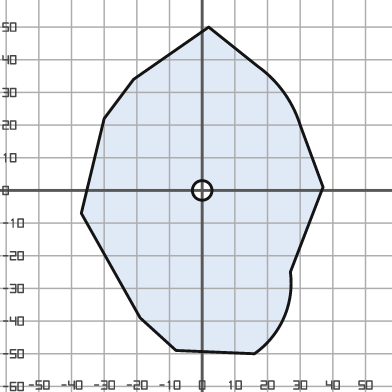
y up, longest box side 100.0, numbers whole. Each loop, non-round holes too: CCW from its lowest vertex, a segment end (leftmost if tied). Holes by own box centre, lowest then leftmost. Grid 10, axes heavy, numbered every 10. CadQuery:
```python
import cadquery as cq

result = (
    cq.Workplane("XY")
    .moveTo(16.0, -50.0)
    .threePointArc((25.0, -39.0), (27.0, -25.0))
    .lineTo(37.0, 1.0)
    .lineTo(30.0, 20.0)
    .threePointArc((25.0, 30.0), (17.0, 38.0))
    .lineTo(2.0, 50.0)
    .lineTo(-21.0, 34.0)
    .lineTo(-30.0, 22.0)
    .lineTo(-37.0, -7.0)
    .lineTo(-19.0, -39.0)
    .lineTo(-8.0, -49.0)
    .close()
    .moveTo(0.0, 0.0)
    .circle(3.0)
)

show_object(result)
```